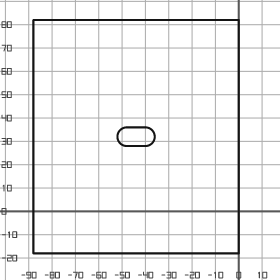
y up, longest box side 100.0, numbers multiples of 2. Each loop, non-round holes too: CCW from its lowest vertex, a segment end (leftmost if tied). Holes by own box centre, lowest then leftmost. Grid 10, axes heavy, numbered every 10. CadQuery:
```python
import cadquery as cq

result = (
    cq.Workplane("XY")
    .moveTo(-88.0, -18.0)
    .lineTo(0.0, -18.0)
    .lineTo(0.0, 82.0)
    .lineTo(-88.0, 82.0)
    .close()
    .moveTo(-48.0, 28.0)
    .lineTo(-40.0, 28.0)
    .threePointArc((-36.0, 32.0), (-40.0, 36.0))
    .lineTo(-48.0, 36.0)
    .threePointArc((-52.0, 32.0), (-48.0, 28.0))
    .close()
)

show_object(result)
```